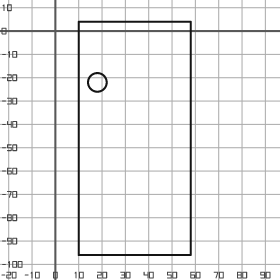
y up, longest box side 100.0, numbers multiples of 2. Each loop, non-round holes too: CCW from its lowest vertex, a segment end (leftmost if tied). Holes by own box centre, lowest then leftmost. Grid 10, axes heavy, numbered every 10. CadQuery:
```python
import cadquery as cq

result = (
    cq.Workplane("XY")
    .moveTo(10.0, -96.0)
    .lineTo(58.0, -96.0)
    .lineTo(58.0, 4.0)
    .lineTo(10.0, 4.0)
    .close()
    .moveTo(18.0, -22.0)
    .circle(4.0)
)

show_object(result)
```